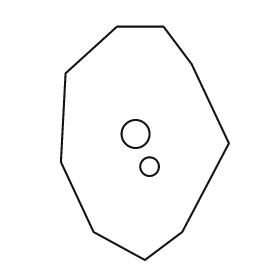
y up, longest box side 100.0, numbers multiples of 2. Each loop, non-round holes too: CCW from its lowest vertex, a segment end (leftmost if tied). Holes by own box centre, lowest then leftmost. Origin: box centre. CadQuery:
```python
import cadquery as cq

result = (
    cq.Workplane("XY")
    .moveTo(0.0, -50.0)
    .lineTo(16.0, -38.0)
    .lineTo(36.0, 0.0)
    .lineTo(20.0, 34.0)
    .lineTo(8.0, 50.0)
    .lineTo(-12.0, 50.0)
    .lineTo(-34.0, 30.0)
    .lineTo(-36.0, -8.0)
    .lineTo(-22.0, -38.0)
    .close()
    .moveTo(2.0, -10.0)
    .circle(4.0)
    .moveTo(-4.0, 4.0)
    .circle(6.0)
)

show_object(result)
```